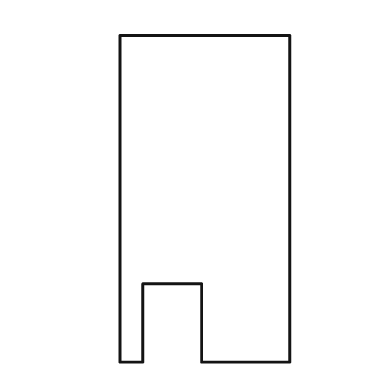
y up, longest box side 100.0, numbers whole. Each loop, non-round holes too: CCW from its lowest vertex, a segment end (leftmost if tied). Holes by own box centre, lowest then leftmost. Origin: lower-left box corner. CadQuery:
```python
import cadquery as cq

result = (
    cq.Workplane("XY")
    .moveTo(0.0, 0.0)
    .lineTo(7.0, 0.0)
    .lineTo(7.0, 24.0)
    .lineTo(25.0, 24.0)
    .lineTo(25.0, 0.0)
    .lineTo(52.0, 0.0)
    .lineTo(52.0, 100.0)
    .lineTo(0.0, 100.0)
    .close()
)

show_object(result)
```